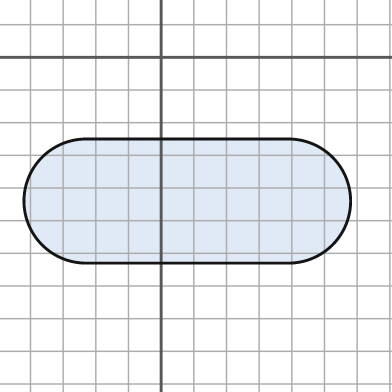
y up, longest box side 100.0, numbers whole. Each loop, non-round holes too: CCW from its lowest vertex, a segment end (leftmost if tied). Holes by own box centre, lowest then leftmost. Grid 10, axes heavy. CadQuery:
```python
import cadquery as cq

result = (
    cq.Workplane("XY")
    .moveTo(-23.0, -63.0)
    .lineTo(39.0, -63.0)
    .threePointArc((58.0, -44.0), (39.0, -25.0))
    .lineTo(-23.0, -25.0)
    .threePointArc((-42.0, -44.0), (-23.0, -63.0))
    .close()
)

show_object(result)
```